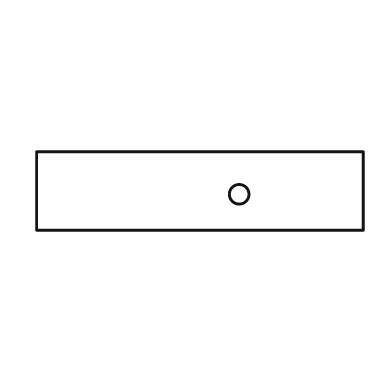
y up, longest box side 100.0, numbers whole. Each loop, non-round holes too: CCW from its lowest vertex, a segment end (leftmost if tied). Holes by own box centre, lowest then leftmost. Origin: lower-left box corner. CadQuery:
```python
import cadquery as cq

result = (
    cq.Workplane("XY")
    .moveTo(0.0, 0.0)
    .lineTo(100.0, 0.0)
    .lineTo(100.0, 24.0)
    .lineTo(0.0, 24.0)
    .close()
    .moveTo(62.0, 11.0)
    .circle(3.0)
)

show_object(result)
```